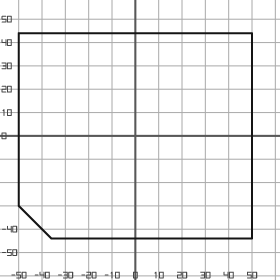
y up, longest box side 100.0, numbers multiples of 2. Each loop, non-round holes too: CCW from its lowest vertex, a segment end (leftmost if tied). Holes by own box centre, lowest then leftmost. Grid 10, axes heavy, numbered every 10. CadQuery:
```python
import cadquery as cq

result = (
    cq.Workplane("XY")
    .moveTo(-36.0, -44.0)
    .lineTo(50.0, -44.0)
    .lineTo(50.0, 44.0)
    .lineTo(-50.0, 44.0)
    .lineTo(-50.0, -30.0)
    .close()
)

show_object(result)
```